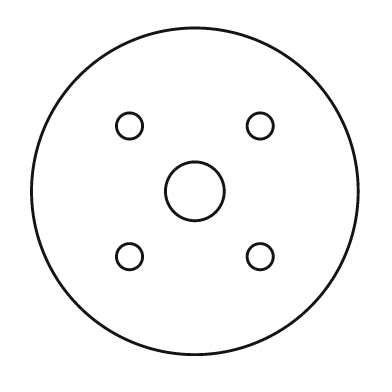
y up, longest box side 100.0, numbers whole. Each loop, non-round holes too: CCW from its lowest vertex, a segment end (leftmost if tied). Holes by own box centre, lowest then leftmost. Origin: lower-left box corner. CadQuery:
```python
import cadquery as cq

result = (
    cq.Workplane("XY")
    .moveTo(50.0, 50.0)
    .circle(50.0)
    .moveTo(30.0, 30.0)
    .circle(4.0)
    .moveTo(70.0, 30.0)
    .circle(4.0)
    .moveTo(50.0, 50.0)
    .circle(9.0)
    .moveTo(30.0, 70.0)
    .circle(4.0)
    .moveTo(70.0, 70.0)
    .circle(4.0)
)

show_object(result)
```